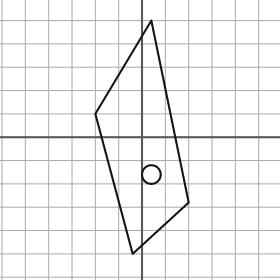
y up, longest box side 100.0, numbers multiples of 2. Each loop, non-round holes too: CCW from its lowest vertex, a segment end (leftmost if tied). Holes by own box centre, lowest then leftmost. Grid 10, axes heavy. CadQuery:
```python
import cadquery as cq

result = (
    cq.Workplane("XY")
    .moveTo(-4.0, -50.0)
    .lineTo(20.0, -28.0)
    .lineTo(4.0, 50.0)
    .lineTo(-20.0, 10.0)
    .close()
    .moveTo(4.0, -16.0)
    .circle(4.0)
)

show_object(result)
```